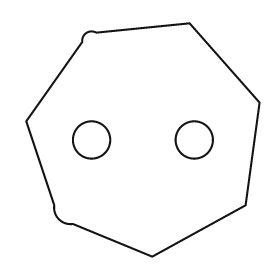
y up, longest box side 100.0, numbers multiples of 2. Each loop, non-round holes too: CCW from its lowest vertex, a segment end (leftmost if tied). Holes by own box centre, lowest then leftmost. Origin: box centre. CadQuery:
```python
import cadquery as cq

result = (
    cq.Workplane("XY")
    .moveTo(4.0, -50.0)
    .lineTo(44.0, -28.0)
    .lineTo(50.0, 16.0)
    .lineTo(20.0, 50.0)
    .lineTo(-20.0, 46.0)
    .threePointArc((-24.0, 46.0), (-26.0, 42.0))
    .lineTo(-50.0, 8.0)
    .lineTo(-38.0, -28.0)
    .threePointArc((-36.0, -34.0), (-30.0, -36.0))
    .close()
    .moveTo(-22.0, 0.0)
    .circle(8.0)
    .moveTo(22.0, 0.0)
    .circle(8.0)
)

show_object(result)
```